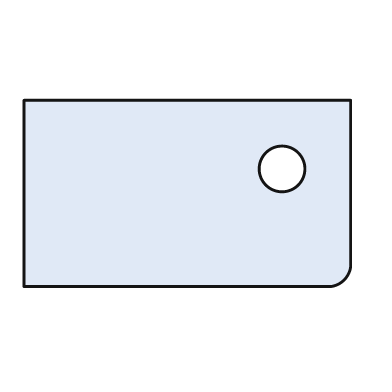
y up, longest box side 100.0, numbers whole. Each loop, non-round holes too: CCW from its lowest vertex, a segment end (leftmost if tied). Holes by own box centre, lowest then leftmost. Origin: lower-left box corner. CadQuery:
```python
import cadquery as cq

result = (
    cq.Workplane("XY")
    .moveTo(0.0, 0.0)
    .lineTo(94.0, 0.0)
    .threePointArc((98.0, 2.0), (100.0, 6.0))
    .lineTo(100.0, 57.0)
    .lineTo(0.0, 57.0)
    .close()
    .moveTo(79.0, 36.0)
    .circle(7.0)
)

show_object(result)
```